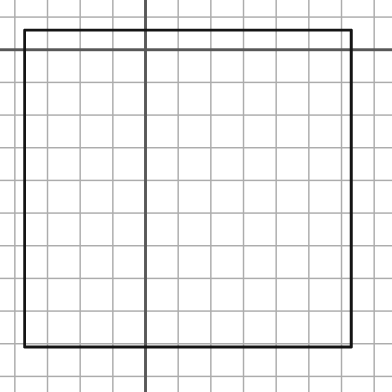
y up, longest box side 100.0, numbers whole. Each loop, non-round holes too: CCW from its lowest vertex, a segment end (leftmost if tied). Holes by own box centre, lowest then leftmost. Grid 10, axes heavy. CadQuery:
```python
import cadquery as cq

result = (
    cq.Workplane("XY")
    .moveTo(-37.0, -91.0)
    .lineTo(63.0, -91.0)
    .lineTo(63.0, 6.0)
    .lineTo(-37.0, 6.0)
    .close()
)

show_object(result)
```